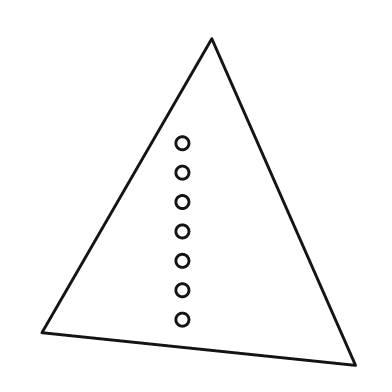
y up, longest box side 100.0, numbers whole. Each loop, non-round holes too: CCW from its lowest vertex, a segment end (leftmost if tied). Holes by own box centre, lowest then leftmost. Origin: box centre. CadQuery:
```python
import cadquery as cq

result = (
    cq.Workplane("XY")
    .moveTo(48.0, -50.0)
    .lineTo(4.0, 50.0)
    .lineTo(-48.0, -40.0)
    .close()
    .moveTo(-5.0, -36.0)
    .circle(2.0)
    .moveTo(-5.0, -27.0)
    .circle(2.0)
    .moveTo(-5.0, -18.0)
    .circle(2.0)
    .moveTo(-5.0, -9.0)
    .circle(2.0)
    .moveTo(-5.0, 0.0)
    .circle(2.0)
    .moveTo(-5.0, 9.0)
    .circle(2.0)
    .moveTo(-5.0, 18.0)
    .circle(2.0)
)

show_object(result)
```